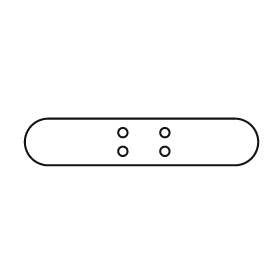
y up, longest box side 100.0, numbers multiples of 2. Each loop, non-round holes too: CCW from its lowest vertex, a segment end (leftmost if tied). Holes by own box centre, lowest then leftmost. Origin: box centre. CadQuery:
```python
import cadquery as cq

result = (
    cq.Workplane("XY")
    .moveTo(-40.0, -10.0)
    .lineTo(40.0, -10.0)
    .threePointArc((50.0, 0.0), (40.0, 10.0))
    .lineTo(-40.0, 10.0)
    .threePointArc((-50.0, 0.0), (-40.0, -10.0))
    .close()
    .moveTo(-8.0, -4.0)
    .circle(2.0)
    .moveTo(10.0, -4.0)
    .circle(2.0)
    .moveTo(-8.0, 4.0)
    .circle(2.0)
    .moveTo(10.0, 4.0)
    .circle(2.0)
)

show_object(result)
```